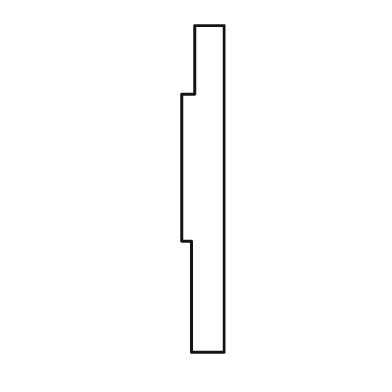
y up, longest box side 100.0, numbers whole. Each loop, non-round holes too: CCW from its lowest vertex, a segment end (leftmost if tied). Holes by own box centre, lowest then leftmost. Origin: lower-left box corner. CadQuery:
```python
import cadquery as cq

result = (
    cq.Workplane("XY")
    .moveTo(3.0, 0.0)
    .lineTo(13.0, 0.0)
    .lineTo(13.0, 100.0)
    .lineTo(4.0, 100.0)
    .lineTo(4.0, 79.0)
    .lineTo(0.0, 79.0)
    .lineTo(0.0, 34.0)
    .lineTo(3.0, 34.0)
    .close()
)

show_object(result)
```